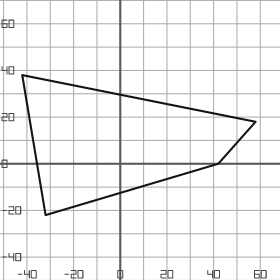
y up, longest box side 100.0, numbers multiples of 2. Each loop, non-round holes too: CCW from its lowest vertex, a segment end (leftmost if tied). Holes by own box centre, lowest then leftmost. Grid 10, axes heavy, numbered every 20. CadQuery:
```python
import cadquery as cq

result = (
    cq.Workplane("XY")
    .moveTo(-32.0, -22.0)
    .lineTo(42.0, 0.0)
    .lineTo(58.0, 18.0)
    .lineTo(-42.0, 38.0)
    .close()
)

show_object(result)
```